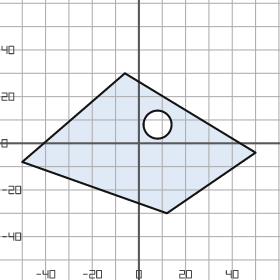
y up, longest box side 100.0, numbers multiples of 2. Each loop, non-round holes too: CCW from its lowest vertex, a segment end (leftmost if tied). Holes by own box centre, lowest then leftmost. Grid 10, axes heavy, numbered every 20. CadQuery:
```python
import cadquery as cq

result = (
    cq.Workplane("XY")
    .moveTo(12.0, -30.0)
    .lineTo(50.0, -4.0)
    .lineTo(-6.0, 30.0)
    .lineTo(-50.0, -8.0)
    .close()
    .moveTo(8.0, 8.0)
    .circle(6.0)
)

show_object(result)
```